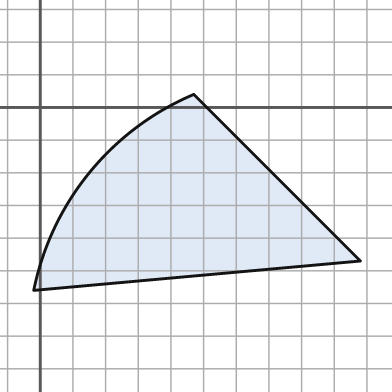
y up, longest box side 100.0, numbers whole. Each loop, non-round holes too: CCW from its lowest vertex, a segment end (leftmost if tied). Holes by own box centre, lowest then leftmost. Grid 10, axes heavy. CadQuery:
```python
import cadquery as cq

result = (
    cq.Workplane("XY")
    .moveTo(-2.0, -56.0)
    .lineTo(98.0, -47.0)
    .lineTo(47.0, 4.0)
    .threePointArc((15.0, -20.0), (-2.0, -56.0))
    .close()
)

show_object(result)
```